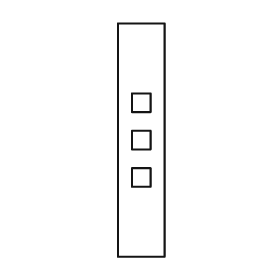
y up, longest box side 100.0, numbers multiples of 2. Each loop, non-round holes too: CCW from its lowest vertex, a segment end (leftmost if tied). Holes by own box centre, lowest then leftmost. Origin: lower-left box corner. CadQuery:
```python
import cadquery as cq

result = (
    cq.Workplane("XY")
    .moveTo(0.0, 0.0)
    .lineTo(20.0, 0.0)
    .lineTo(20.0, 100.0)
    .lineTo(0.0, 100.0)
    .close()
    .moveTo(6.0, 30.0)
    .lineTo(14.0, 30.0)
    .lineTo(14.0, 38.0)
    .lineTo(6.0, 38.0)
    .close()
    .moveTo(6.0, 46.0)
    .lineTo(14.0, 46.0)
    .lineTo(14.0, 54.0)
    .lineTo(6.0, 54.0)
    .close()
    .moveTo(6.0, 62.0)
    .lineTo(14.0, 62.0)
    .lineTo(14.0, 70.0)
    .lineTo(6.0, 70.0)
    .close()
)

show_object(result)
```